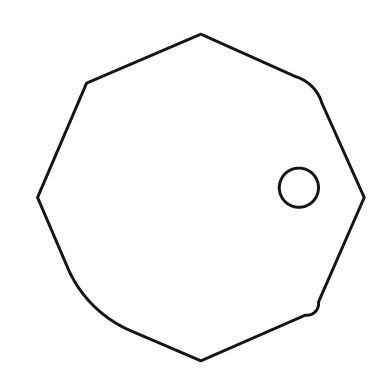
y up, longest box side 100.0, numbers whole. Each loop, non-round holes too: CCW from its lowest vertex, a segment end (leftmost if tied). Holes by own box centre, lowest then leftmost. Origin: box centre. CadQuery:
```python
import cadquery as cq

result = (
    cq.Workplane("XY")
    .moveTo(0.0, -50.0)
    .lineTo(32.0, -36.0)
    .threePointArc((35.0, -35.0), (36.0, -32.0))
    .lineTo(50.0, 0.0)
    .lineTo(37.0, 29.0)
    .threePointArc((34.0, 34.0), (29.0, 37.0))
    .lineTo(0.0, 50.0)
    .lineTo(-35.0, 35.0)
    .lineTo(-50.0, 0.0)
    .lineTo(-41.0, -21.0)
    .threePointArc((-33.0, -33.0), (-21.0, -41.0))
    .close()
    .moveTo(30.0, 3.0)
    .circle(6.0)
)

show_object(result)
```